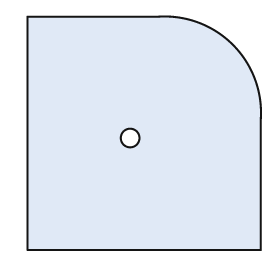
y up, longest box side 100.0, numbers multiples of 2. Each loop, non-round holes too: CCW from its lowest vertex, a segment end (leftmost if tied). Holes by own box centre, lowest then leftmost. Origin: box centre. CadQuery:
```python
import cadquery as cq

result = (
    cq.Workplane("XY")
    .moveTo(-50.0, -50.0)
    .lineTo(50.0, -50.0)
    .lineTo(50.0, 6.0)
    .threePointArc((38.0, 38.0), (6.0, 50.0))
    .lineTo(-50.0, 50.0)
    .close()
    .moveTo(-6.0, -2.0)
    .circle(4.0)
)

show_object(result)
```